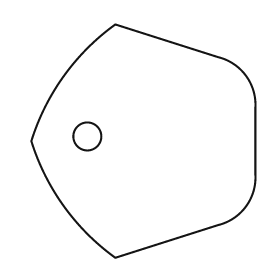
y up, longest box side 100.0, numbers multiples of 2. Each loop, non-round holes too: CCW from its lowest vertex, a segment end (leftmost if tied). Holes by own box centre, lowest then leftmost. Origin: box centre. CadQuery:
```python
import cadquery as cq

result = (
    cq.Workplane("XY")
    .moveTo(-12.0, -50.0)
    .lineTo(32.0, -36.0)
    .threePointArc((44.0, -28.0), (48.0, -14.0))
    .lineTo(48.0, 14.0)
    .threePointArc((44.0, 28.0), (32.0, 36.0))
    .lineTo(-12.0, 50.0)
    .threePointArc((-34.0, 28.0), (-48.0, 0.0))
    .threePointArc((-34.0, -28.0), (-12.0, -50.0))
    .close()
    .moveTo(-24.0, 2.0)
    .circle(6.0)
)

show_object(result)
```